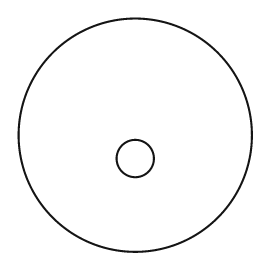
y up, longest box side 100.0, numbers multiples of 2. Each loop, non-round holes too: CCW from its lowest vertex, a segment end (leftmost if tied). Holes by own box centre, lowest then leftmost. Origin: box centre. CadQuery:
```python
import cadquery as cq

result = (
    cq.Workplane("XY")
    .moveTo(0.0, 0.0)
    .circle(50.0)
    .moveTo(0.0, -10.0)
    .circle(8.0)
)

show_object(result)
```